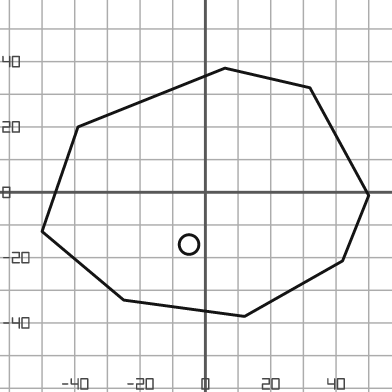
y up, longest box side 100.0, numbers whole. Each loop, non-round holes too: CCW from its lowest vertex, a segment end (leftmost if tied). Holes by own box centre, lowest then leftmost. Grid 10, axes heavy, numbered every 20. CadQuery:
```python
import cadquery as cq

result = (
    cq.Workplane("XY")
    .moveTo(12.0, -38.0)
    .lineTo(42.0, -21.0)
    .lineTo(50.0, -1.0)
    .lineTo(32.0, 32.0)
    .lineTo(6.0, 38.0)
    .lineTo(-39.0, 20.0)
    .lineTo(-50.0, -12.0)
    .lineTo(-25.0, -33.0)
    .close()
    .moveTo(-5.0, -16.0)
    .circle(3.0)
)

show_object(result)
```